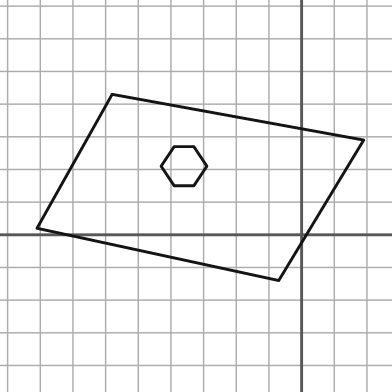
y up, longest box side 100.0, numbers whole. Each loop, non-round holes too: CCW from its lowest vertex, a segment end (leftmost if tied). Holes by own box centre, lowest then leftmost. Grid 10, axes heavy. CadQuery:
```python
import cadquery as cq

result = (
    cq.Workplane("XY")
    .moveTo(-7.0, -14.0)
    .lineTo(19.0, 29.0)
    .lineTo(-58.0, 43.0)
    .lineTo(-81.0, 2.0)
    .close()
    .moveTo(-39.0, 15.0)
    .lineTo(-33.0, 15.0)
    .lineTo(-29.0, 21.0)
    .lineTo(-33.0, 27.0)
    .lineTo(-39.0, 27.0)
    .lineTo(-43.0, 21.0)
    .close()
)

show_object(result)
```